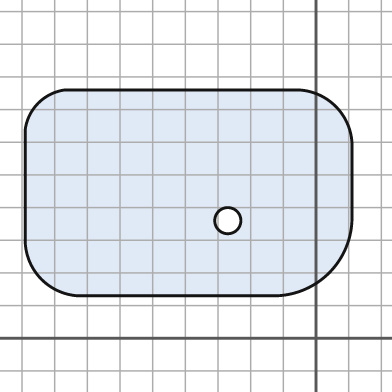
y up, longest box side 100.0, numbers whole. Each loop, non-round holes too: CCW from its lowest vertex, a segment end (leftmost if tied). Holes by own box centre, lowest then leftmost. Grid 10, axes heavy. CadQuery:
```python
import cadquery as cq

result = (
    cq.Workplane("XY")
    .moveTo(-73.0, 13.0)
    .lineTo(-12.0, 13.0)
    .threePointArc((4.0, 20.0), (11.0, 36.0))
    .lineTo(11.0, 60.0)
    .threePointArc((6.0, 71.0), (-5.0, 76.0))
    .lineTo(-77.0, 76.0)
    .threePointArc((-85.0, 72.0), (-89.0, 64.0))
    .lineTo(-89.0, 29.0)
    .threePointArc((-84.0, 18.0), (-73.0, 13.0))
    .close()
    .moveTo(-27.0, 36.0)
    .circle(4.0)
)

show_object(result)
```